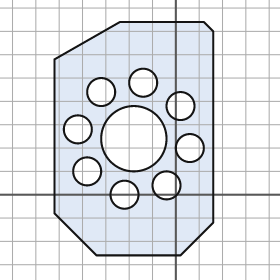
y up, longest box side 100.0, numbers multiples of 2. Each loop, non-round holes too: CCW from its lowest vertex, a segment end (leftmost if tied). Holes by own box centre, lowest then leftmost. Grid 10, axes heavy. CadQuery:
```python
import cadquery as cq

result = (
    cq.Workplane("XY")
    .moveTo(-34.0, -26.0)
    .lineTo(2.0, -26.0)
    .lineTo(16.0, -12.0)
    .lineTo(16.0, 70.0)
    .lineTo(12.0, 74.0)
    .lineTo(-24.0, 74.0)
    .lineTo(-52.0, 58.0)
    .lineTo(-52.0, -8.0)
    .close()
    .moveTo(-22.0, 0.0)
    .circle(6.0)
    .moveTo(-4.0, 4.0)
    .circle(6.0)
    .moveTo(-38.0, 10.0)
    .circle(6.0)
    .moveTo(6.0, 20.0)
    .circle(6.0)
    .moveTo(-18.0, 24.0)
    .circle(14.0)
    .moveTo(-42.0, 28.0)
    .circle(6.0)
    .moveTo(2.0, 38.0)
    .circle(6.0)
    .moveTo(-32.0, 44.0)
    .circle(6.0)
    .moveTo(-14.0, 48.0)
    .circle(6.0)
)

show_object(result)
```